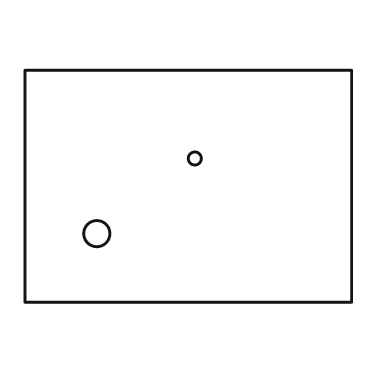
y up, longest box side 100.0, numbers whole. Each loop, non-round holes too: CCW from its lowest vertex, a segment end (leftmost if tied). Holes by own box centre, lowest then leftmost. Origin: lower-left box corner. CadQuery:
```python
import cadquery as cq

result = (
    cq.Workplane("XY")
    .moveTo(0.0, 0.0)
    .lineTo(100.0, 0.0)
    .lineTo(100.0, 71.0)
    .lineTo(0.0, 71.0)
    .close()
    .moveTo(22.0, 21.0)
    .circle(4.0)
    .moveTo(52.0, 44.0)
    .circle(2.0)
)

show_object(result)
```